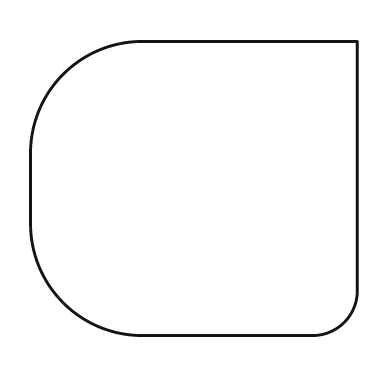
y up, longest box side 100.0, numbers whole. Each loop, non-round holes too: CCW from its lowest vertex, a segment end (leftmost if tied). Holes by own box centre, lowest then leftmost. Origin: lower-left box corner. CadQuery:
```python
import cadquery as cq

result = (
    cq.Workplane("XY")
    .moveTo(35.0, 0.0)
    .lineTo(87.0, 0.0)
    .threePointArc((96.0, 4.0), (100.0, 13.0))
    .lineTo(100.0, 90.0)
    .lineTo(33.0, 90.0)
    .threePointArc((10.0, 80.0), (0.0, 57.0))
    .lineTo(0.0, 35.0)
    .threePointArc((10.0, 10.0), (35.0, 0.0))
    .close()
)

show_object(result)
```